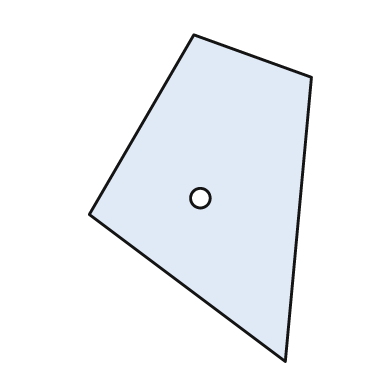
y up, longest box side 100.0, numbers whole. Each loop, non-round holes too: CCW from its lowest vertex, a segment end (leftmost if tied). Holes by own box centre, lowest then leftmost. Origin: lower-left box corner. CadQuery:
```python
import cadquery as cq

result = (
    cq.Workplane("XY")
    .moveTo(60.0, 0.0)
    .lineTo(68.0, 87.0)
    .lineTo(32.0, 100.0)
    .lineTo(0.0, 45.0)
    .close()
    .moveTo(34.0, 50.0)
    .circle(3.0)
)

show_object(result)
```